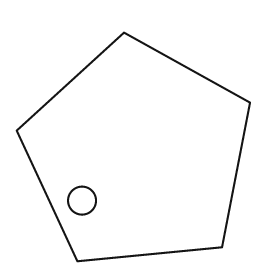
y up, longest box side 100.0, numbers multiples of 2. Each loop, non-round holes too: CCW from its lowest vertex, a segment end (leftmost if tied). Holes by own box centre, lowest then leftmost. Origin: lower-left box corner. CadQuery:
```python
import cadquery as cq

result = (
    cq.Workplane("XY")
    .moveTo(26.0, 0.0)
    .lineTo(88.0, 6.0)
    .lineTo(100.0, 68.0)
    .lineTo(46.0, 98.0)
    .lineTo(0.0, 56.0)
    .close()
    .moveTo(28.0, 26.0)
    .circle(6.0)
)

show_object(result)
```